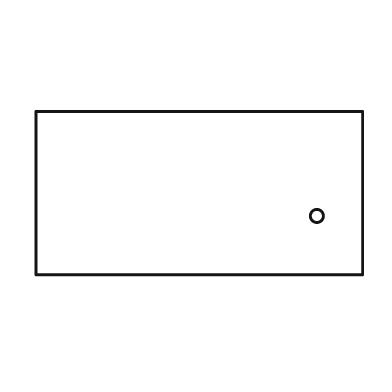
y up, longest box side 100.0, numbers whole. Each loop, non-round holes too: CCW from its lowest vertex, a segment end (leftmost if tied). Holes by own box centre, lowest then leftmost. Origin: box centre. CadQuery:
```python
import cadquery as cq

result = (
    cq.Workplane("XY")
    .moveTo(-50.0, -25.0)
    .lineTo(50.0, -25.0)
    .lineTo(50.0, 25.0)
    .lineTo(-50.0, 25.0)
    .close()
    .moveTo(36.0, -7.0)
    .circle(2.0)
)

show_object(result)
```